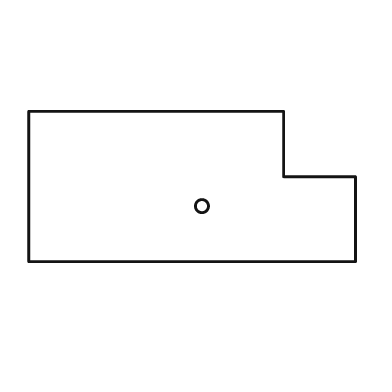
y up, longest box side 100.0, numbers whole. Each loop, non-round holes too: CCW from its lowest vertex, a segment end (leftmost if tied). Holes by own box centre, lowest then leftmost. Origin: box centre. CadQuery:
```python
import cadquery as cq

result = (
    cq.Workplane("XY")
    .moveTo(-50.0, -23.0)
    .lineTo(50.0, -23.0)
    .lineTo(50.0, 3.0)
    .lineTo(28.0, 3.0)
    .lineTo(28.0, 23.0)
    .lineTo(-50.0, 23.0)
    .close()
    .moveTo(3.0, -6.0)
    .circle(2.0)
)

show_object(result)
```